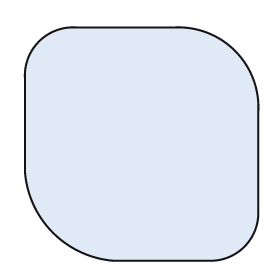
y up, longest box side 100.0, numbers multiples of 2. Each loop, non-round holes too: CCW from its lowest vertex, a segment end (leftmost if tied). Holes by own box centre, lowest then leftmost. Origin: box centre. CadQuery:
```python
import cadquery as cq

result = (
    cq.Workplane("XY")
    .moveTo(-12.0, -50.0)
    .lineTo(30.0, -50.0)
    .threePointArc((44.0, -44.0), (50.0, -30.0))
    .lineTo(50.0, 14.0)
    .threePointArc((40.0, 40.0), (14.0, 50.0))
    .lineTo(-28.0, 50.0)
    .threePointArc((-44.0, 44.0), (-50.0, 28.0))
    .lineTo(-50.0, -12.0)
    .threePointArc((-38.0, -38.0), (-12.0, -50.0))
    .close()
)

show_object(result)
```